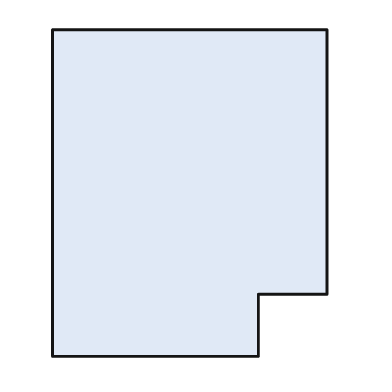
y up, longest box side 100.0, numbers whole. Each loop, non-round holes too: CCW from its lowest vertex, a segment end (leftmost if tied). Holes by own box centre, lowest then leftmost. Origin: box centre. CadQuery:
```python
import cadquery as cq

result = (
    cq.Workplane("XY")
    .moveTo(-42.0, -50.0)
    .lineTo(21.0, -50.0)
    .lineTo(21.0, -31.0)
    .lineTo(42.0, -31.0)
    .lineTo(42.0, 50.0)
    .lineTo(-42.0, 50.0)
    .close()
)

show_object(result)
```